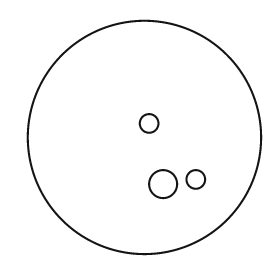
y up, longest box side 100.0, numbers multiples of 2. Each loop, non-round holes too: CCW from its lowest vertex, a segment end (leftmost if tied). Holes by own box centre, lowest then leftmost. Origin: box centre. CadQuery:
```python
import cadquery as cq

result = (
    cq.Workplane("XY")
    .moveTo(0.0, 0.0)
    .circle(50.0)
    .moveTo(8.0, -20.0)
    .circle(6.0)
    .moveTo(22.0, -18.0)
    .circle(4.0)
    .moveTo(2.0, 6.0)
    .circle(4.0)
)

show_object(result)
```